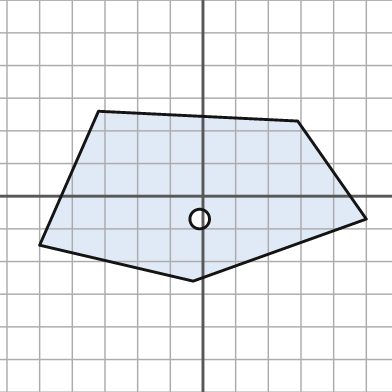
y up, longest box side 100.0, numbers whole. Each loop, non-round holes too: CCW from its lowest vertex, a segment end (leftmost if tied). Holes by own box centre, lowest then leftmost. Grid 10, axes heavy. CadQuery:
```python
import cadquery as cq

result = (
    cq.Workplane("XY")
    .moveTo(-3.0, -26.0)
    .lineTo(50.0, -7.0)
    .lineTo(29.0, 23.0)
    .lineTo(-32.0, 26.0)
    .lineTo(-50.0, -15.0)
    .close()
    .moveTo(-1.0, -7.0)
    .circle(3.0)
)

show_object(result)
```